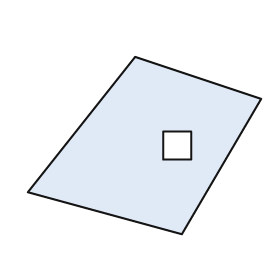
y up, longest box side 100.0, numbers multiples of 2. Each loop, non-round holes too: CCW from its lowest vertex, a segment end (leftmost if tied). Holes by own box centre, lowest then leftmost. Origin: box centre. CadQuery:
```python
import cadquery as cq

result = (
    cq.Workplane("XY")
    .moveTo(16.0, -38.0)
    .lineTo(50.0, 20.0)
    .lineTo(-4.0, 38.0)
    .lineTo(-50.0, -20.0)
    .close()
    .moveTo(8.0, -6.0)
    .lineTo(20.0, -6.0)
    .lineTo(20.0, 6.0)
    .lineTo(8.0, 6.0)
    .close()
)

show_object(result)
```